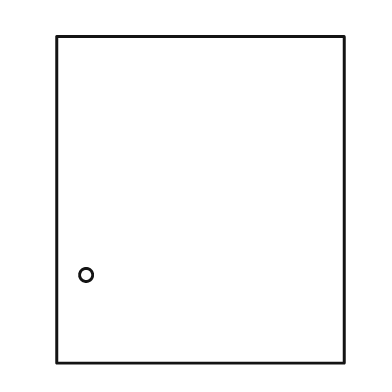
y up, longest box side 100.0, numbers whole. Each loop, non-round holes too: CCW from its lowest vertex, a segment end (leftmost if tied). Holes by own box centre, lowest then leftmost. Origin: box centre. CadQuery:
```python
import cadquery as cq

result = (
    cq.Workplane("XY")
    .moveTo(-44.0, -50.0)
    .lineTo(44.0, -50.0)
    .lineTo(44.0, 50.0)
    .lineTo(-44.0, 50.0)
    .close()
    .moveTo(-35.0, -23.0)
    .circle(2.0)
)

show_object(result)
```